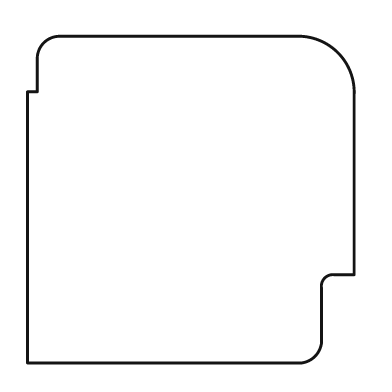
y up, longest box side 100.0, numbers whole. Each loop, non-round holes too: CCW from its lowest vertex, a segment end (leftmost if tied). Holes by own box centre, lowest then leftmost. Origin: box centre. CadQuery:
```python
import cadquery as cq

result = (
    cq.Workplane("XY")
    .moveTo(-50.0, -50.0)
    .lineTo(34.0, -50.0)
    .threePointArc((38.0, -48.0), (40.0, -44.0))
    .lineTo(40.0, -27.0)
    .threePointArc((41.0, -24.0), (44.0, -23.0))
    .lineTo(50.0, -23.0)
    .lineTo(50.0, 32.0)
    .threePointArc((45.0, 45.0), (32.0, 50.0))
    .lineTo(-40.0, 50.0)
    .threePointArc((-45.0, 48.0), (-47.0, 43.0))
    .lineTo(-47.0, 33.0)
    .lineTo(-50.0, 33.0)
    .close()
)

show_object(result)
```